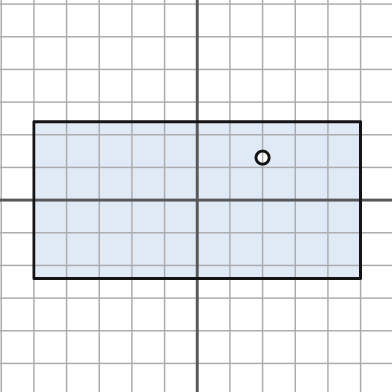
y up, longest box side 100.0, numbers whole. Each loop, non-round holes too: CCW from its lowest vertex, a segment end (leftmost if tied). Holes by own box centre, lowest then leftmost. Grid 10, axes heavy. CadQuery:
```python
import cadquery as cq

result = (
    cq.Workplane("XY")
    .moveTo(-50.0, -24.0)
    .lineTo(50.0, -24.0)
    .lineTo(50.0, 24.0)
    .lineTo(-50.0, 24.0)
    .close()
    .moveTo(20.0, 13.0)
    .circle(2.0)
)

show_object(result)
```